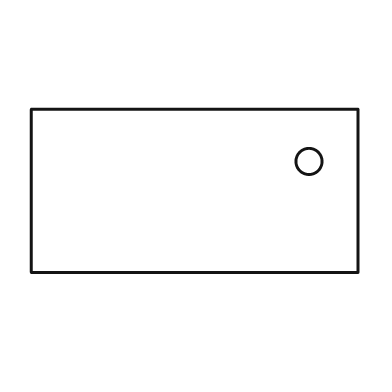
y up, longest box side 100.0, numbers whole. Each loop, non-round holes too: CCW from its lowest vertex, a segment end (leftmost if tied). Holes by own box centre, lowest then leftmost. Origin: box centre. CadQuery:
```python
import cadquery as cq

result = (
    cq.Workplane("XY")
    .moveTo(-50.0, -25.0)
    .lineTo(50.0, -25.0)
    .lineTo(50.0, 25.0)
    .lineTo(-50.0, 25.0)
    .close()
    .moveTo(35.0, 9.0)
    .circle(4.0)
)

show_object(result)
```